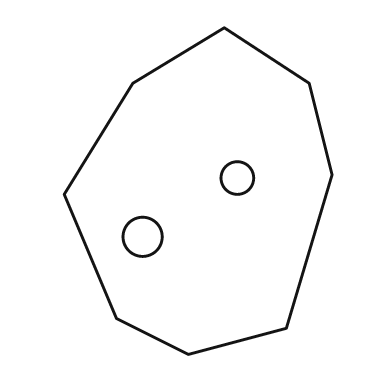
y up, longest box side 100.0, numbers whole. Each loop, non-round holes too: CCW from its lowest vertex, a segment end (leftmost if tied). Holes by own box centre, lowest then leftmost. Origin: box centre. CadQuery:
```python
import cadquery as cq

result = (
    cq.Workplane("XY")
    .moveTo(-3.0, -50.0)
    .lineTo(27.0, -42.0)
    .lineTo(41.0, 5.0)
    .lineTo(34.0, 33.0)
    .lineTo(8.0, 50.0)
    .lineTo(-20.0, 33.0)
    .lineTo(-41.0, -1.0)
    .lineTo(-25.0, -39.0)
    .close()
    .moveTo(-17.0, -14.0)
    .circle(6.0)
    .moveTo(12.0, 4.0)
    .circle(5.0)
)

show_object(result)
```